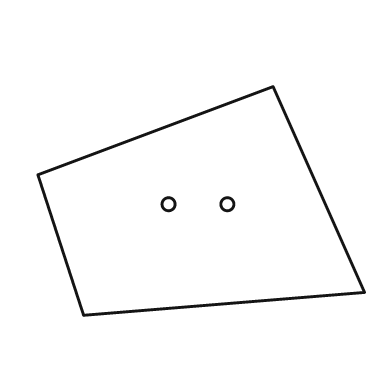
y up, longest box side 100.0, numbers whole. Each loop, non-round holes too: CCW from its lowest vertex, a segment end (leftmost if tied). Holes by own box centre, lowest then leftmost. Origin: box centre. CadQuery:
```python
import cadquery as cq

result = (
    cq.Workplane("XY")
    .moveTo(-36.0, -35.0)
    .lineTo(50.0, -28.0)
    .lineTo(22.0, 35.0)
    .lineTo(-50.0, 8.0)
    .close()
    .moveTo(-10.0, -1.0)
    .circle(2.0)
    .moveTo(8.0, -1.0)
    .circle(2.0)
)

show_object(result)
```